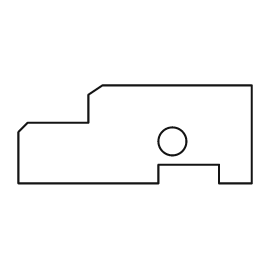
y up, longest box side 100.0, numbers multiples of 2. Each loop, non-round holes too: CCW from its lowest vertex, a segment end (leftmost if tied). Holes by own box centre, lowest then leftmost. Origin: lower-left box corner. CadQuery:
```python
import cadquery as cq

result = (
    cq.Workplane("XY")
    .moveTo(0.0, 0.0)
    .lineTo(60.0, 0.0)
    .lineTo(60.0, 8.0)
    .lineTo(86.0, 8.0)
    .lineTo(86.0, 0.0)
    .lineTo(100.0, 0.0)
    .lineTo(100.0, 42.0)
    .lineTo(36.0, 42.0)
    .lineTo(30.0, 38.0)
    .lineTo(30.0, 26.0)
    .lineTo(4.0, 26.0)
    .lineTo(0.0, 22.0)
    .close()
    .moveTo(66.0, 18.0)
    .circle(6.0)
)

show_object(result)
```